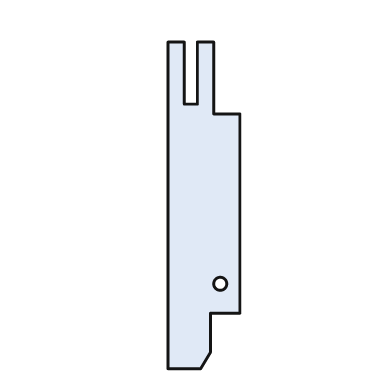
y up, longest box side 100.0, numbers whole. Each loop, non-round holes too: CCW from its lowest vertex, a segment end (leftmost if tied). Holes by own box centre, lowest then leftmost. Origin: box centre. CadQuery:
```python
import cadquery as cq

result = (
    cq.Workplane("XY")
    .moveTo(-11.0, -50.0)
    .lineTo(-1.0, -50.0)
    .lineTo(2.0, -45.0)
    .lineTo(2.0, -33.0)
    .lineTo(11.0, -33.0)
    .lineTo(11.0, 28.0)
    .lineTo(3.0, 28.0)
    .lineTo(3.0, 50.0)
    .lineTo(-2.0, 50.0)
    .lineTo(-2.0, 31.0)
    .lineTo(-6.0, 31.0)
    .lineTo(-6.0, 50.0)
    .lineTo(-11.0, 50.0)
    .close()
    .moveTo(5.0, -24.0)
    .circle(2.0)
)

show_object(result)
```